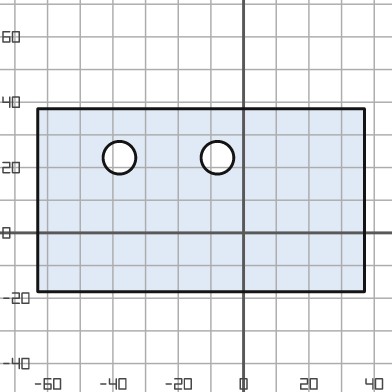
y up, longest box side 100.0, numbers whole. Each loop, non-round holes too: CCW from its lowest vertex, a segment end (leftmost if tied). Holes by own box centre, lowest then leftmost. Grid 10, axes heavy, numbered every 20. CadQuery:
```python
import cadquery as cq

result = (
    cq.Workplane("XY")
    .moveTo(-63.0, -18.0)
    .lineTo(37.0, -18.0)
    .lineTo(37.0, 38.0)
    .lineTo(-63.0, 38.0)
    .close()
    .moveTo(-38.0, 23.0)
    .circle(5.0)
    .moveTo(-8.0, 23.0)
    .circle(5.0)
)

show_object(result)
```